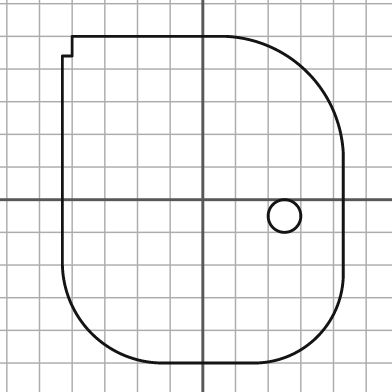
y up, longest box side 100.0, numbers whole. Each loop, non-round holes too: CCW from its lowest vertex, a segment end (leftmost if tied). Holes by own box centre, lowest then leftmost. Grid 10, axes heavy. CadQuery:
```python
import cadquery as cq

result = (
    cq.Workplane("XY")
    .moveTo(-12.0, -50.0)
    .lineTo(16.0, -50.0)
    .threePointArc((35.0, -42.0), (43.0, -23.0))
    .lineTo(43.0, 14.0)
    .threePointArc((32.0, 39.0), (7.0, 50.0))
    .lineTo(-40.0, 50.0)
    .lineTo(-40.0, 44.0)
    .lineTo(-43.0, 44.0)
    .lineTo(-43.0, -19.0)
    .threePointArc((-34.0, -41.0), (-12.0, -50.0))
    .close()
    .moveTo(25.0, -5.0)
    .circle(5.0)
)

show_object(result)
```